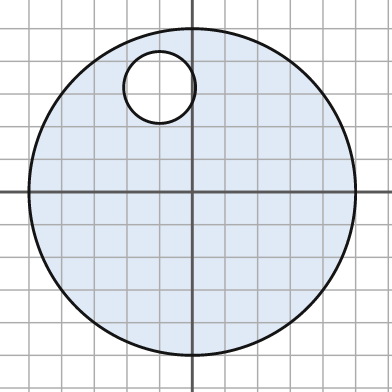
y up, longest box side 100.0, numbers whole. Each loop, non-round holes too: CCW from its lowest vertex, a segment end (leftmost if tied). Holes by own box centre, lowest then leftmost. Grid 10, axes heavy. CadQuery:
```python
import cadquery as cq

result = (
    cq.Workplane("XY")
    .moveTo(0.0, 0.0)
    .circle(50.0)
    .moveTo(-10.0, 32.0)
    .circle(11.0)
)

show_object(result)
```